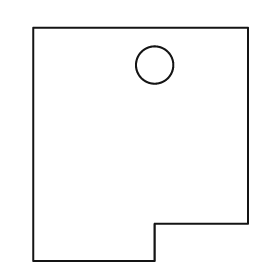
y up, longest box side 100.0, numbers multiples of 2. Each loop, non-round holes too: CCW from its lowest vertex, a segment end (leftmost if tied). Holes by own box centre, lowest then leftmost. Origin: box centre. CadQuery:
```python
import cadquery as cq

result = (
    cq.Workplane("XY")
    .moveTo(-46.0, -50.0)
    .lineTo(6.0, -50.0)
    .lineTo(6.0, -34.0)
    .lineTo(46.0, -34.0)
    .lineTo(46.0, 50.0)
    .lineTo(-46.0, 50.0)
    .close()
    .moveTo(6.0, 34.0)
    .circle(8.0)
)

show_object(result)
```